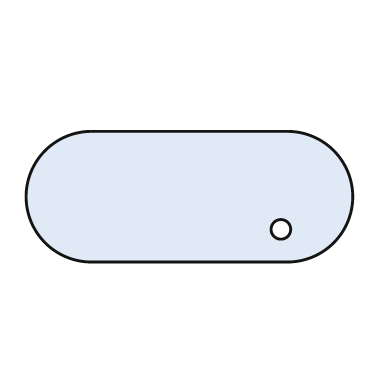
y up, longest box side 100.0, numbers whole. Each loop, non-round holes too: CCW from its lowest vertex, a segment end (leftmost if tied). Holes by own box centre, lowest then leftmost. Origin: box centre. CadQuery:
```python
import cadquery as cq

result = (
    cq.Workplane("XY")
    .moveTo(-30.0, -20.0)
    .lineTo(30.0, -20.0)
    .threePointArc((50.0, 0.0), (30.0, 20.0))
    .lineTo(-30.0, 20.0)
    .threePointArc((-50.0, 0.0), (-30.0, -20.0))
    .close()
    .moveTo(28.0, -10.0)
    .circle(3.0)
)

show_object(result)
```